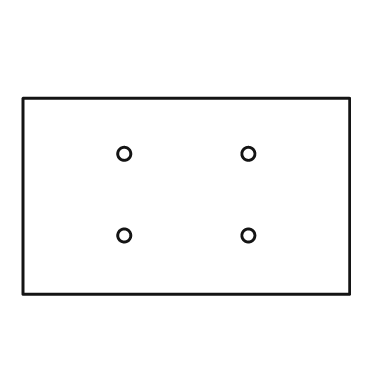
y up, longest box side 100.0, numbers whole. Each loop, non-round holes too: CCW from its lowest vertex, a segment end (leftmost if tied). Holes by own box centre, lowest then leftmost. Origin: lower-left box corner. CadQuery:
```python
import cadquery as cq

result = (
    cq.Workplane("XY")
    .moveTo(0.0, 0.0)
    .lineTo(100.0, 0.0)
    .lineTo(100.0, 60.0)
    .lineTo(0.0, 60.0)
    .close()
    .moveTo(31.0, 18.0)
    .circle(2.0)
    .moveTo(69.0, 18.0)
    .circle(2.0)
    .moveTo(31.0, 43.0)
    .circle(2.0)
    .moveTo(69.0, 43.0)
    .circle(2.0)
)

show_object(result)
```